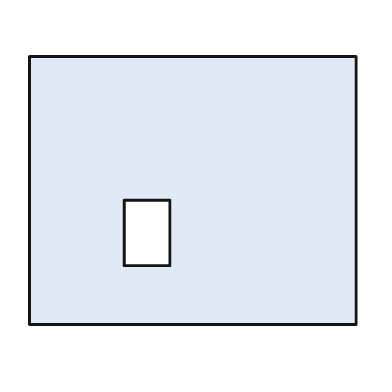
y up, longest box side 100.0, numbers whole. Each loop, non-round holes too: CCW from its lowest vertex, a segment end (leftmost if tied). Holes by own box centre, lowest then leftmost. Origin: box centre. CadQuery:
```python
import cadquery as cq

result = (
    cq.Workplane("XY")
    .moveTo(-50.0, -41.0)
    .lineTo(50.0, -41.0)
    .lineTo(50.0, 41.0)
    .lineTo(-50.0, 41.0)
    .close()
    .moveTo(-21.0, -23.0)
    .lineTo(-7.0, -23.0)
    .lineTo(-7.0, -3.0)
    .lineTo(-21.0, -3.0)
    .close()
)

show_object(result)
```